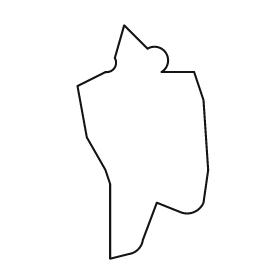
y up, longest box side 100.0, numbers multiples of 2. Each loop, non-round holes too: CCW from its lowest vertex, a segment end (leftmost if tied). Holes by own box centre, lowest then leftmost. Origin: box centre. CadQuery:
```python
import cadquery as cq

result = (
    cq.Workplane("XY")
    .moveTo(-14.0, -50.0)
    .lineTo(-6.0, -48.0)
    .threePointArc((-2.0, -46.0), (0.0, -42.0))
    .lineTo(6.0, -26.0)
    .lineTo(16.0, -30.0)
    .threePointArc((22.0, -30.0), (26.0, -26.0))
    .lineTo(28.0, -12.0)
    .lineTo(26.0, 18.0)
    .lineTo(22.0, 30.0)
    .lineTo(8.0, 30.0)
    .threePointArc((10.0, 38.0), (2.0, 40.0))
    .lineTo(-8.0, 50.0)
    .lineTo(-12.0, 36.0)
    .threePointArc((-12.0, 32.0), (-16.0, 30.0))
    .lineTo(-28.0, 24.0)
    .lineTo(-24.0, 2.0)
    .lineTo(-16.0, -12.0)
    .lineTo(-14.0, -18.0)
    .close()
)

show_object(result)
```